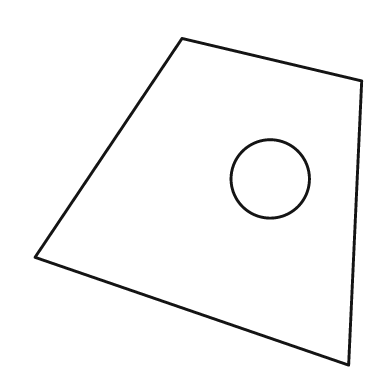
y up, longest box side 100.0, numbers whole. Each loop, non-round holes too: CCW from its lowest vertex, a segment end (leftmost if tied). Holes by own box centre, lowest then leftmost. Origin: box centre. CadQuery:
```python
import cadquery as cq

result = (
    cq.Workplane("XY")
    .moveTo(46.0, -50.0)
    .lineTo(50.0, 37.0)
    .lineTo(-5.0, 50.0)
    .lineTo(-50.0, -17.0)
    .close()
    .moveTo(22.0, 7.0)
    .circle(12.0)
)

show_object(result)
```